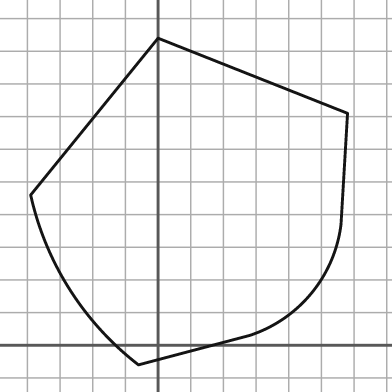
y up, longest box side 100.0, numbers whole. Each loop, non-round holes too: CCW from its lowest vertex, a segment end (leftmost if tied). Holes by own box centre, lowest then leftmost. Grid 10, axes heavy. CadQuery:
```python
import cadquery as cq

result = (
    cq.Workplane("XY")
    .moveTo(-6.0, -6.0)
    .lineTo(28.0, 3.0)
    .threePointArc((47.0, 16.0), (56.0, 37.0))
    .lineTo(58.0, 71.0)
    .lineTo(0.0, 94.0)
    .lineTo(-39.0, 46.0)
    .threePointArc((-27.0, 17.0), (-6.0, -6.0))
    .close()
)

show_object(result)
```